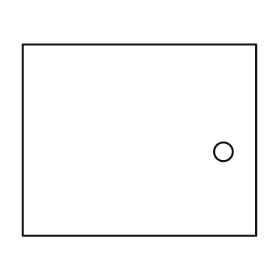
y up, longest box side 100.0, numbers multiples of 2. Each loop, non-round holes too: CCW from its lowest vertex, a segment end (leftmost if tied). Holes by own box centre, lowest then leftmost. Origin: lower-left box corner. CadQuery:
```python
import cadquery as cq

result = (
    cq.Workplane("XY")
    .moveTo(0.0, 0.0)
    .lineTo(100.0, 0.0)
    .lineTo(100.0, 82.0)
    .lineTo(0.0, 82.0)
    .close()
    .moveTo(86.0, 36.0)
    .circle(4.0)
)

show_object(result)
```